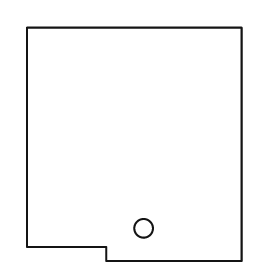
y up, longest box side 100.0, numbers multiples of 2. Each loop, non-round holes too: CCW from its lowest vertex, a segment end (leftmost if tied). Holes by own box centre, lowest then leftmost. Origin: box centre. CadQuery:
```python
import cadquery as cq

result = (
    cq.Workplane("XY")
    .moveTo(-12.0, -50.0)
    .lineTo(46.0, -50.0)
    .lineTo(46.0, 50.0)
    .lineTo(-46.0, 50.0)
    .lineTo(-46.0, -44.0)
    .lineTo(-12.0, -44.0)
    .close()
    .moveTo(4.0, -36.0)
    .circle(4.0)
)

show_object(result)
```